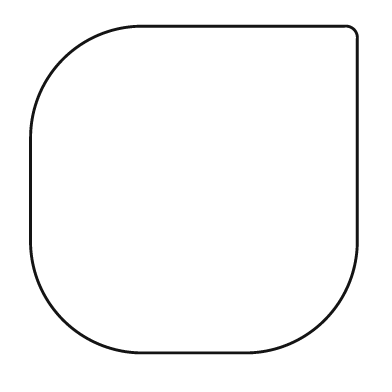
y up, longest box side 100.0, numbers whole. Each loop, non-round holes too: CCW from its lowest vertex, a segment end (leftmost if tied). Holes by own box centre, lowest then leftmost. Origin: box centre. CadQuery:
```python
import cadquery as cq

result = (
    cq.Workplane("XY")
    .moveTo(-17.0, -50.0)
    .lineTo(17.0, -50.0)
    .threePointArc((40.0, -40.0), (50.0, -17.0))
    .lineTo(50.0, 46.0)
    .threePointArc((49.0, 49.0), (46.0, 50.0))
    .lineTo(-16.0, 50.0)
    .threePointArc((-40.0, 40.0), (-50.0, 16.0))
    .lineTo(-50.0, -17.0)
    .threePointArc((-40.0, -40.0), (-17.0, -50.0))
    .close()
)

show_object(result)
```